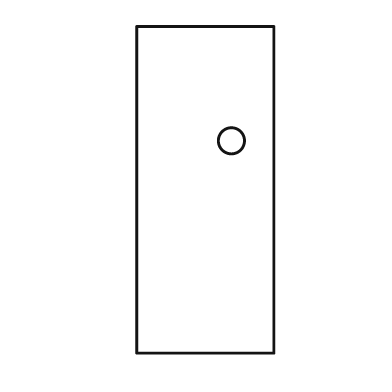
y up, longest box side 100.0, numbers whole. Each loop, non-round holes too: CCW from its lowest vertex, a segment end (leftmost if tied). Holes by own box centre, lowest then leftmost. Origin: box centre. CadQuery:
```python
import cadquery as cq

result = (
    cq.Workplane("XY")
    .moveTo(-21.0, -50.0)
    .lineTo(21.0, -50.0)
    .lineTo(21.0, 50.0)
    .lineTo(-21.0, 50.0)
    .close()
    .moveTo(8.0, 15.0)
    .circle(4.0)
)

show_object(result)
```